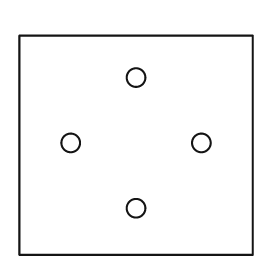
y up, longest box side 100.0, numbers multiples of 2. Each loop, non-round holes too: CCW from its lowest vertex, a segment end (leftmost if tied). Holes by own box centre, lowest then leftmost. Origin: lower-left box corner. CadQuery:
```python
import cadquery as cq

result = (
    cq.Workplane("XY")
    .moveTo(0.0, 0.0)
    .lineTo(100.0, 0.0)
    .lineTo(100.0, 94.0)
    .lineTo(0.0, 94.0)
    .close()
    .moveTo(50.0, 20.0)
    .circle(4.0)
    .moveTo(22.0, 48.0)
    .circle(4.0)
    .moveTo(78.0, 48.0)
    .circle(4.0)
    .moveTo(50.0, 76.0)
    .circle(4.0)
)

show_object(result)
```